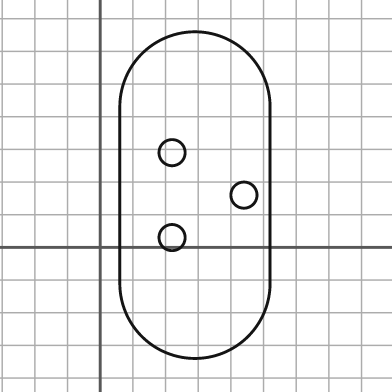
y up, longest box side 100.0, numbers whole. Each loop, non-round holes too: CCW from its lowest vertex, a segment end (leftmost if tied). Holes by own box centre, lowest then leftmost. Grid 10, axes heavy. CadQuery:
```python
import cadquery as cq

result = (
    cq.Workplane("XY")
    .moveTo(6.0, -11.0)
    .threePointArc((29.0, -34.0), (52.0, -11.0))
    .lineTo(52.0, 43.0)
    .threePointArc((29.0, 66.0), (6.0, 43.0))
    .close()
    .moveTo(22.0, 3.0)
    .circle(4.0)
    .moveTo(44.0, 16.0)
    .circle(4.0)
    .moveTo(22.0, 29.0)
    .circle(4.0)
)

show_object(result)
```